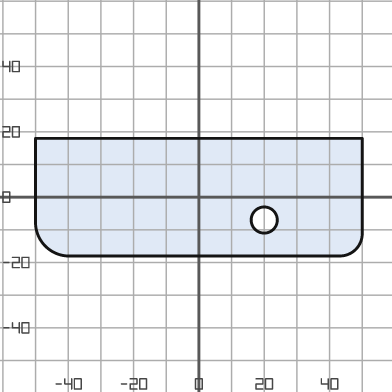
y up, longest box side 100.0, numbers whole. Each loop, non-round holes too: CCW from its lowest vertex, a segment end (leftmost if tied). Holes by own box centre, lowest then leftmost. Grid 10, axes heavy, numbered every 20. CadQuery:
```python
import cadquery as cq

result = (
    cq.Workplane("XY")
    .moveTo(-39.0, -18.0)
    .lineTo(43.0, -18.0)
    .threePointArc((48.0, -16.0), (50.0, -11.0))
    .lineTo(50.0, 18.0)
    .lineTo(-50.0, 18.0)
    .lineTo(-50.0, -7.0)
    .threePointArc((-47.0, -15.0), (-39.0, -18.0))
    .close()
    .moveTo(20.0, -7.0)
    .circle(4.0)
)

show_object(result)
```